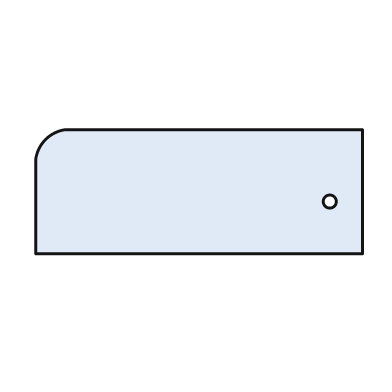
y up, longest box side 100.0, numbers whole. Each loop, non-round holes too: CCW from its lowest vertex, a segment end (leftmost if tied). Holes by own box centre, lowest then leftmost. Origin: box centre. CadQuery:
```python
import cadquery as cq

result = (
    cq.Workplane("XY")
    .moveTo(-50.0, -19.0)
    .lineTo(50.0, -19.0)
    .lineTo(50.0, 19.0)
    .lineTo(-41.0, 19.0)
    .threePointArc((-47.0, 16.0), (-50.0, 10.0))
    .close()
    .moveTo(40.0, -3.0)
    .circle(2.0)
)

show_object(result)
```